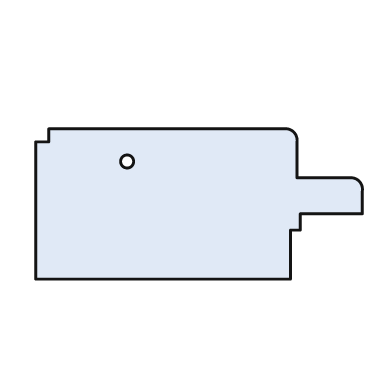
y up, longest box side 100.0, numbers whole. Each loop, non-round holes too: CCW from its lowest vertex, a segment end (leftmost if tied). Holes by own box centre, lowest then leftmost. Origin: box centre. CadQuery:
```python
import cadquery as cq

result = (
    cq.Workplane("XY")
    .moveTo(-50.0, -23.0)
    .lineTo(28.0, -23.0)
    .lineTo(28.0, -8.0)
    .lineTo(31.0, -8.0)
    .lineTo(31.0, -3.0)
    .lineTo(50.0, -3.0)
    .lineTo(50.0, 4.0)
    .threePointArc((49.0, 7.0), (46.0, 8.0))
    .lineTo(30.0, 8.0)
    .lineTo(30.0, 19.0)
    .threePointArc((29.0, 22.0), (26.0, 23.0))
    .lineTo(-46.0, 23.0)
    .lineTo(-46.0, 19.0)
    .lineTo(-50.0, 19.0)
    .close()
    .moveTo(-22.0, 13.0)
    .circle(2.0)
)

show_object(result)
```